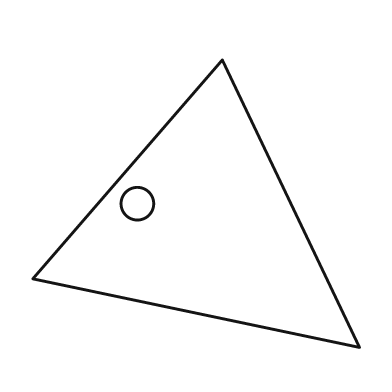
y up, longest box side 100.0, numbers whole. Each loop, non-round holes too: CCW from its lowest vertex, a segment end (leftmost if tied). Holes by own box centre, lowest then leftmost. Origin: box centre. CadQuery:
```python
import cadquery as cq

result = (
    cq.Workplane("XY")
    .moveTo(50.0, -44.0)
    .lineTo(8.0, 44.0)
    .lineTo(-50.0, -23.0)
    .close()
    .moveTo(-18.0, 0.0)
    .circle(5.0)
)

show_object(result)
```